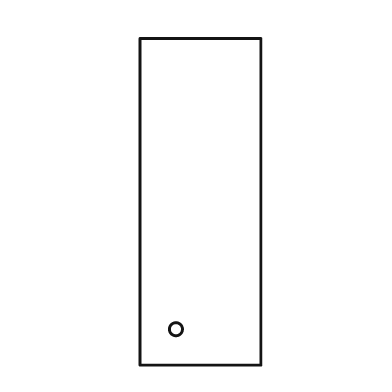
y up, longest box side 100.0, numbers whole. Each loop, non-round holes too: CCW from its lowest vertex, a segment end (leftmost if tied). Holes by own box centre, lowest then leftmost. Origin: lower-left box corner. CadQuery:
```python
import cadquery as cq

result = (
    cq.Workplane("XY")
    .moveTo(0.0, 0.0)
    .lineTo(37.0, 0.0)
    .lineTo(37.0, 100.0)
    .lineTo(0.0, 100.0)
    .close()
    .moveTo(11.0, 11.0)
    .circle(2.0)
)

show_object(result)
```